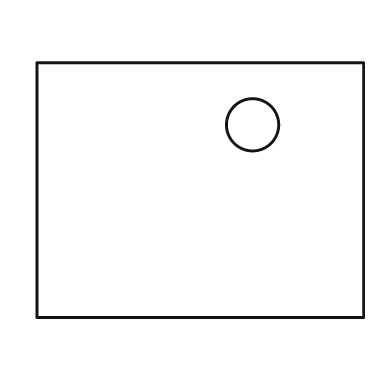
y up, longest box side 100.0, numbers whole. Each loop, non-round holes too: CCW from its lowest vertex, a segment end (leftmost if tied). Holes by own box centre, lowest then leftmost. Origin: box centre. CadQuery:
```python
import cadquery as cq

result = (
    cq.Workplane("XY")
    .moveTo(-50.0, -39.0)
    .lineTo(50.0, -39.0)
    .lineTo(50.0, 39.0)
    .lineTo(-50.0, 39.0)
    .close()
    .moveTo(16.0, 20.0)
    .circle(8.0)
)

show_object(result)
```